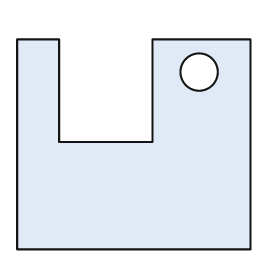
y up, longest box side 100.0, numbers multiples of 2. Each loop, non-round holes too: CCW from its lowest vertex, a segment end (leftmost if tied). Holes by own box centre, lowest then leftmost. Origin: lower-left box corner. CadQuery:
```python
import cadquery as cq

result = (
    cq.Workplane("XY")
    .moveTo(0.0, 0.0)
    .lineTo(100.0, 0.0)
    .lineTo(100.0, 90.0)
    .lineTo(58.0, 90.0)
    .lineTo(58.0, 46.0)
    .lineTo(18.0, 46.0)
    .lineTo(18.0, 90.0)
    .lineTo(0.0, 90.0)
    .close()
    .moveTo(78.0, 76.0)
    .circle(8.0)
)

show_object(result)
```